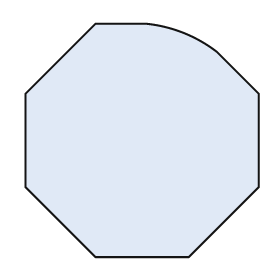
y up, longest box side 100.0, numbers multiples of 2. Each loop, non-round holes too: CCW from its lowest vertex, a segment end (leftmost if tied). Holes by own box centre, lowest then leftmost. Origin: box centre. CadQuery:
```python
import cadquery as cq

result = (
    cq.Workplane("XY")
    .moveTo(-20.0, -50.0)
    .lineTo(20.0, -50.0)
    .lineTo(50.0, -20.0)
    .lineTo(50.0, 20.0)
    .lineTo(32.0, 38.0)
    .threePointArc((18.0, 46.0), (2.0, 50.0))
    .lineTo(-20.0, 50.0)
    .lineTo(-50.0, 20.0)
    .lineTo(-50.0, -20.0)
    .close()
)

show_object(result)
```